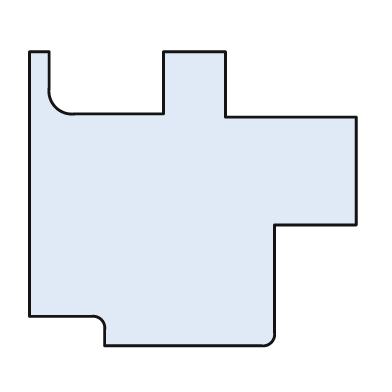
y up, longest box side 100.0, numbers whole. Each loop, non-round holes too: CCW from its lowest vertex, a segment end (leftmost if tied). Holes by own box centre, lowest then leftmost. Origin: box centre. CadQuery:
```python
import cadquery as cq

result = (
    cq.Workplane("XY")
    .moveTo(-27.0, -45.0)
    .lineTo(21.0, -45.0)
    .threePointArc((24.0, -44.0), (25.0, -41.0))
    .lineTo(25.0, -8.0)
    .lineTo(50.0, -8.0)
    .lineTo(50.0, 25.0)
    .lineTo(10.0, 25.0)
    .lineTo(10.0, 45.0)
    .lineTo(-9.0, 45.0)
    .lineTo(-9.0, 26.0)
    .lineTo(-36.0, 26.0)
    .threePointArc((-42.0, 28.0), (-44.0, 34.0))
    .lineTo(-44.0, 45.0)
    .lineTo(-50.0, 45.0)
    .lineTo(-50.0, -36.0)
    .lineTo(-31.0, -36.0)
    .threePointArc((-28.0, -37.0), (-27.0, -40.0))
    .close()
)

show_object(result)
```